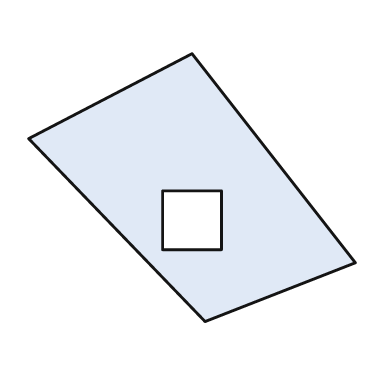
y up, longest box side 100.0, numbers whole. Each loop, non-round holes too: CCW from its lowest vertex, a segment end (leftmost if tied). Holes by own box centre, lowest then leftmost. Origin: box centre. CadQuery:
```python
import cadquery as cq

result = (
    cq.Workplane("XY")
    .moveTo(4.0, -41.0)
    .lineTo(50.0, -23.0)
    .lineTo(0.0, 41.0)
    .lineTo(-50.0, 15.0)
    .close()
    .moveTo(-9.0, -19.0)
    .lineTo(9.0, -19.0)
    .lineTo(9.0, -1.0)
    .lineTo(-9.0, -1.0)
    .close()
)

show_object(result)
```